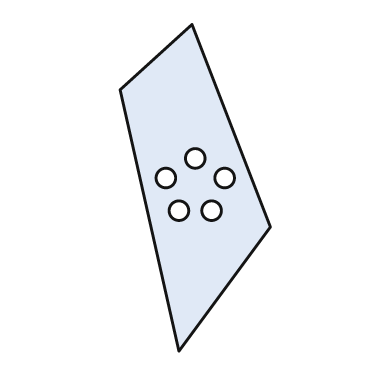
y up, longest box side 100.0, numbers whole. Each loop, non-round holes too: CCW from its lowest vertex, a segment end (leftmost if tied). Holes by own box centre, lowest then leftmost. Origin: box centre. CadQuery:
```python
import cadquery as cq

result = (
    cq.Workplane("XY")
    .moveTo(-5.0, -50.0)
    .lineTo(23.0, -12.0)
    .lineTo(-1.0, 50.0)
    .lineTo(-23.0, 30.0)
    .close()
    .moveTo(-5.0, -7.0)
    .circle(3.0)
    .moveTo(5.0, -7.0)
    .circle(3.0)
    .moveTo(-9.0, 3.0)
    .circle(3.0)
    .moveTo(9.0, 3.0)
    .circle(3.0)
    .moveTo(0.0, 9.0)
    .circle(3.0)
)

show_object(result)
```